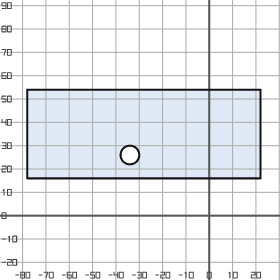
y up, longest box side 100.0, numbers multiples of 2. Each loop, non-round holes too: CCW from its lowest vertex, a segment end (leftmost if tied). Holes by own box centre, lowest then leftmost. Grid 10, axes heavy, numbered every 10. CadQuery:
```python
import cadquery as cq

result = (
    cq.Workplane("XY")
    .moveTo(-78.0, 16.0)
    .lineTo(22.0, 16.0)
    .lineTo(22.0, 54.0)
    .lineTo(-78.0, 54.0)
    .close()
    .moveTo(-34.0, 26.0)
    .circle(4.0)
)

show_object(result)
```